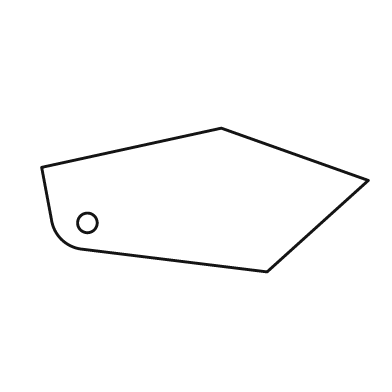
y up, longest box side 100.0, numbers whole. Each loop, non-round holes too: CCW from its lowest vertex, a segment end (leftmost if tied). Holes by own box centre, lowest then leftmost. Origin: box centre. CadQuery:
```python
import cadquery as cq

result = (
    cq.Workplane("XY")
    .moveTo(19.0, -22.0)
    .lineTo(50.0, 6.0)
    .lineTo(5.0, 22.0)
    .lineTo(-50.0, 10.0)
    .lineTo(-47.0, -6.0)
    .threePointArc((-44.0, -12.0), (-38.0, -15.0))
    .close()
    .moveTo(-36.0, -7.0)
    .circle(3.0)
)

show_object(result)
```